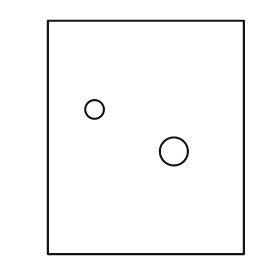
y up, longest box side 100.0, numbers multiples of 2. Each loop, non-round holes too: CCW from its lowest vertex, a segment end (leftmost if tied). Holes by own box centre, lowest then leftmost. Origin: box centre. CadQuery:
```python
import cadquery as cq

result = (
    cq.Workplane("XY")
    .moveTo(-42.0, -50.0)
    .lineTo(42.0, -50.0)
    .lineTo(42.0, 50.0)
    .lineTo(-42.0, 50.0)
    .close()
    .moveTo(12.0, -6.0)
    .circle(6.0)
    .moveTo(-22.0, 12.0)
    .circle(4.0)
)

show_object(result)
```